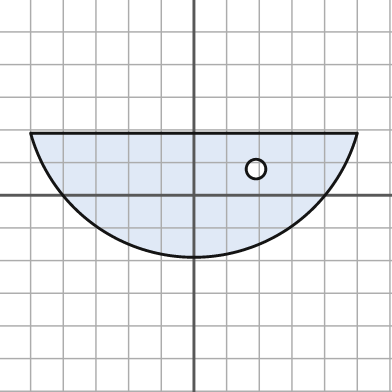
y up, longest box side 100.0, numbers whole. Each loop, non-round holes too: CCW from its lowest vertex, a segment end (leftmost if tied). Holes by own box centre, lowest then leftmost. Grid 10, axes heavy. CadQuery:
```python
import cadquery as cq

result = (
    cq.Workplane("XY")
    .moveTo(-50.0, 19.0)
    .threePointArc((0.0, -19.0), (50.0, 19.0))
    .close()
    .moveTo(19.0, 8.0)
    .circle(3.0)
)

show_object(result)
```